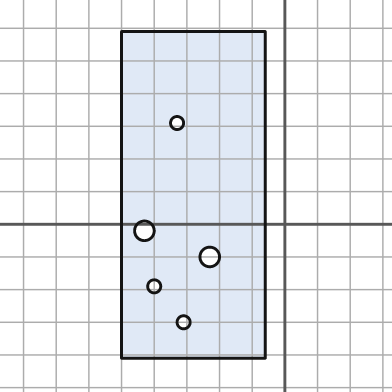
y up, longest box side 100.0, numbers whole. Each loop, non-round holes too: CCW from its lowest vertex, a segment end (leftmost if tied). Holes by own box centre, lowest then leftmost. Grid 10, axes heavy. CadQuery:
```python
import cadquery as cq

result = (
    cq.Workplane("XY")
    .moveTo(-50.0, -41.0)
    .lineTo(-6.0, -41.0)
    .lineTo(-6.0, 59.0)
    .lineTo(-50.0, 59.0)
    .close()
    .moveTo(-31.0, -30.0)
    .circle(2.0)
    .moveTo(-40.0, -19.0)
    .circle(2.0)
    .moveTo(-23.0, -10.0)
    .circle(3.0)
    .moveTo(-43.0, -2.0)
    .circle(3.0)
    .moveTo(-33.0, 31.0)
    .circle(2.0)
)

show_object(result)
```